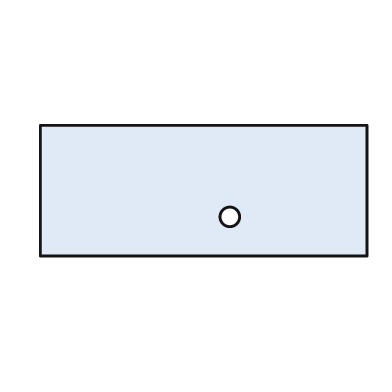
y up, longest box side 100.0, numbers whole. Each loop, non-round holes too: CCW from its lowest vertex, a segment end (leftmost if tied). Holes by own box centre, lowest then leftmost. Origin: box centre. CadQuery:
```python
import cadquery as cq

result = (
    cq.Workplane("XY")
    .moveTo(-50.0, -20.0)
    .lineTo(50.0, -20.0)
    .lineTo(50.0, 20.0)
    .lineTo(-50.0, 20.0)
    .close()
    .moveTo(8.0, -8.0)
    .circle(3.0)
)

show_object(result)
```